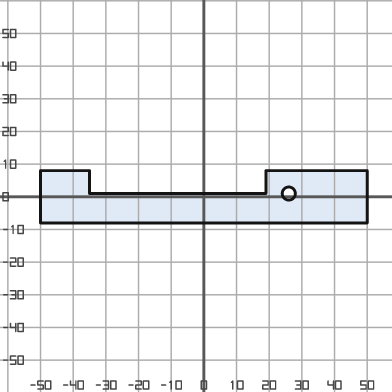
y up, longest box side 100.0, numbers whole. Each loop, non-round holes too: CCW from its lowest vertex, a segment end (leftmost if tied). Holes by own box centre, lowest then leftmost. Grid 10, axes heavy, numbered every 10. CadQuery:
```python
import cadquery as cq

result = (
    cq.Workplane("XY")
    .moveTo(-50.0, -8.0)
    .lineTo(50.0, -8.0)
    .lineTo(50.0, 8.0)
    .lineTo(19.0, 8.0)
    .lineTo(19.0, 1.0)
    .lineTo(-35.0, 1.0)
    .lineTo(-35.0, 8.0)
    .lineTo(-50.0, 8.0)
    .close()
    .moveTo(26.0, 1.0)
    .circle(2.0)
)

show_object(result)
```